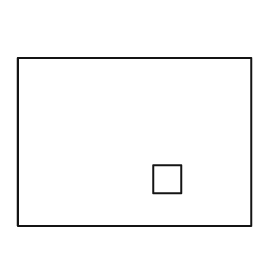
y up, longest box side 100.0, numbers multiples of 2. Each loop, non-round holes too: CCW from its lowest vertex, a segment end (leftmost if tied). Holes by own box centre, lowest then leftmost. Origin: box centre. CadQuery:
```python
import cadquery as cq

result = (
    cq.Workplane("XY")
    .moveTo(-50.0, -36.0)
    .lineTo(50.0, -36.0)
    .lineTo(50.0, 36.0)
    .lineTo(-50.0, 36.0)
    .close()
    .moveTo(8.0, -22.0)
    .lineTo(20.0, -22.0)
    .lineTo(20.0, -10.0)
    .lineTo(8.0, -10.0)
    .close()
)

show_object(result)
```